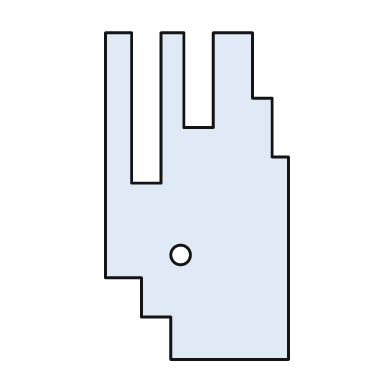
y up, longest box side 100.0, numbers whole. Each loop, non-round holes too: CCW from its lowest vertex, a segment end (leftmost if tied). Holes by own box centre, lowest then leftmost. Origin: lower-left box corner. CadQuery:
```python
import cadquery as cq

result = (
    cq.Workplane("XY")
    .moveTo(20.0, 0.0)
    .lineTo(56.0, 0.0)
    .lineTo(56.0, 62.0)
    .lineTo(51.0, 62.0)
    .lineTo(51.0, 80.0)
    .lineTo(45.0, 80.0)
    .lineTo(45.0, 100.0)
    .lineTo(33.0, 100.0)
    .lineTo(33.0, 71.0)
    .lineTo(24.0, 71.0)
    .lineTo(24.0, 100.0)
    .lineTo(17.0, 100.0)
    .lineTo(17.0, 54.0)
    .lineTo(8.0, 54.0)
    .lineTo(8.0, 100.0)
    .lineTo(0.0, 100.0)
    .lineTo(0.0, 25.0)
    .lineTo(11.0, 25.0)
    .lineTo(11.0, 13.0)
    .lineTo(20.0, 13.0)
    .close()
    .moveTo(23.0, 32.0)
    .circle(3.0)
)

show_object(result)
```